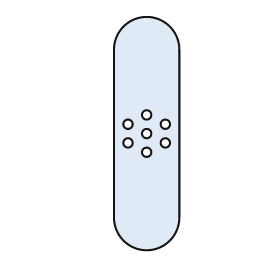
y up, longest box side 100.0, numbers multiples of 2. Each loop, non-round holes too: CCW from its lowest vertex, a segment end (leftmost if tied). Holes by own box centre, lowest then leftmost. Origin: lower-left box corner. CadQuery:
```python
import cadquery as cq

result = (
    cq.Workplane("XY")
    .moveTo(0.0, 14.0)
    .threePointArc((14.0, 0.0), (28.0, 14.0))
    .lineTo(28.0, 86.0)
    .threePointArc((14.0, 100.0), (0.0, 86.0))
    .close()
    .moveTo(14.0, 42.0)
    .circle(2.0)
    .moveTo(6.0, 46.0)
    .circle(2.0)
    .moveTo(22.0, 46.0)
    .circle(2.0)
    .moveTo(14.0, 50.0)
    .circle(2.0)
    .moveTo(6.0, 54.0)
    .circle(2.0)
    .moveTo(22.0, 54.0)
    .circle(2.0)
    .moveTo(14.0, 58.0)
    .circle(2.0)
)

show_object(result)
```